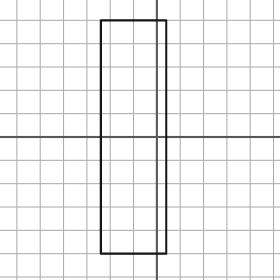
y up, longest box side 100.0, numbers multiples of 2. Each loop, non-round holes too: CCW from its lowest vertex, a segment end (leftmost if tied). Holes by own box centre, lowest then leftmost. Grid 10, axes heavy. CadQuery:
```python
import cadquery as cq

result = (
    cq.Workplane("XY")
    .moveTo(-24.0, -50.0)
    .lineTo(4.0, -50.0)
    .lineTo(4.0, 50.0)
    .lineTo(-24.0, 50.0)
    .close()
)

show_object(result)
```